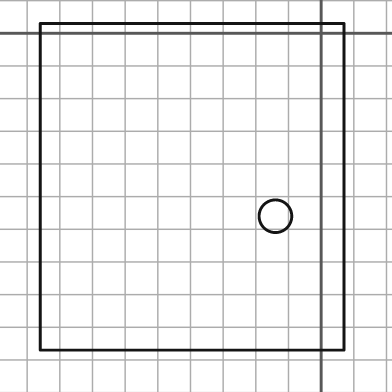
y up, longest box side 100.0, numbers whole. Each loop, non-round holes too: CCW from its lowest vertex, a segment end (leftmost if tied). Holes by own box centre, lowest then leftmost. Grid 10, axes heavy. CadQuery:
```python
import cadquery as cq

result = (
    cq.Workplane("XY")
    .moveTo(-86.0, -97.0)
    .lineTo(7.0, -97.0)
    .lineTo(7.0, 3.0)
    .lineTo(-86.0, 3.0)
    .close()
    .moveTo(-14.0, -56.0)
    .circle(5.0)
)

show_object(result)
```